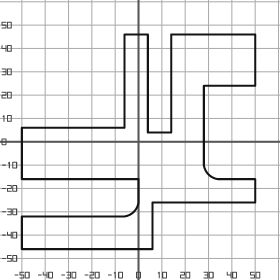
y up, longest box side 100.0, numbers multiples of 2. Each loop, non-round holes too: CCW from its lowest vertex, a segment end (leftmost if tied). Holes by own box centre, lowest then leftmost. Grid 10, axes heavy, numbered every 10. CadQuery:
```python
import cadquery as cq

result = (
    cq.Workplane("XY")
    .moveTo(-50.0, -46.0)
    .lineTo(6.0, -46.0)
    .lineTo(6.0, -26.0)
    .lineTo(50.0, -26.0)
    .lineTo(50.0, -16.0)
    .lineTo(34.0, -16.0)
    .threePointArc((30.0, -14.0), (28.0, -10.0))
    .lineTo(28.0, 24.0)
    .lineTo(50.0, 24.0)
    .lineTo(50.0, 46.0)
    .lineTo(14.0, 46.0)
    .lineTo(14.0, 4.0)
    .lineTo(4.0, 4.0)
    .lineTo(4.0, 46.0)
    .lineTo(-6.0, 46.0)
    .lineTo(-6.0, 6.0)
    .lineTo(-50.0, 6.0)
    .lineTo(-50.0, -16.0)
    .lineTo(0.0, -16.0)
    .lineTo(0.0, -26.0)
    .threePointArc((-2.0, -30.0), (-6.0, -32.0))
    .lineTo(-50.0, -32.0)
    .close()
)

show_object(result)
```